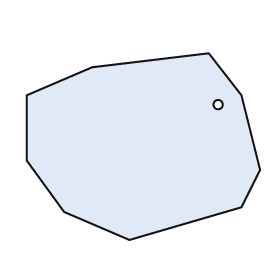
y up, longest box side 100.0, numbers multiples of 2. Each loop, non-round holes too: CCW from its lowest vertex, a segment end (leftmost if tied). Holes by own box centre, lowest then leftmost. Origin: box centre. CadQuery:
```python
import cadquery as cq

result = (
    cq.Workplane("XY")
    .moveTo(-6.0, -40.0)
    .lineTo(42.0, -26.0)
    .lineTo(50.0, -10.0)
    .lineTo(42.0, 22.0)
    .lineTo(28.0, 40.0)
    .lineTo(-22.0, 34.0)
    .lineTo(-50.0, 22.0)
    .lineTo(-50.0, -6.0)
    .lineTo(-34.0, -28.0)
    .close()
    .moveTo(32.0, 18.0)
    .circle(2.0)
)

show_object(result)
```